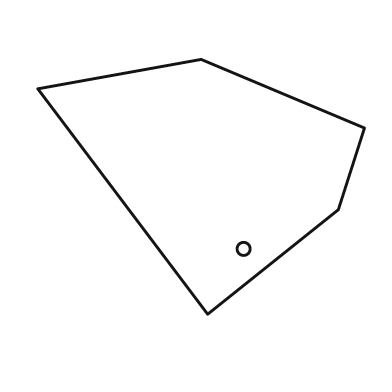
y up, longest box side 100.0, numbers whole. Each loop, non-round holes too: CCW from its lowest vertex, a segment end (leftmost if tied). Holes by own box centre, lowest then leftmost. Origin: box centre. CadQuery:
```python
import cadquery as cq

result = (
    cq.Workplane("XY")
    .moveTo(2.0, -39.0)
    .lineTo(42.0, -7.0)
    .lineTo(50.0, 18.0)
    .lineTo(0.0, 39.0)
    .lineTo(-50.0, 30.0)
    .close()
    .moveTo(13.0, -19.0)
    .circle(2.0)
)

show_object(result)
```